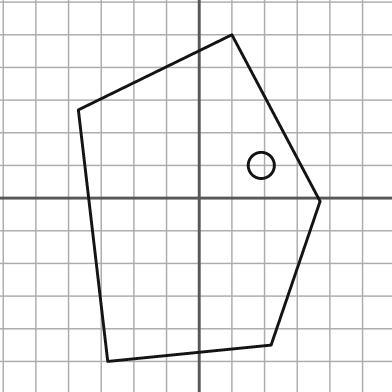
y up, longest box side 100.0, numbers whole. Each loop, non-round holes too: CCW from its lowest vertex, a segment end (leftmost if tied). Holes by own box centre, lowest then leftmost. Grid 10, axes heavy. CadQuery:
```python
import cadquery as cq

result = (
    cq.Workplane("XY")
    .moveTo(-28.0, -50.0)
    .lineTo(22.0, -45.0)
    .lineTo(37.0, -1.0)
    .lineTo(10.0, 50.0)
    .lineTo(-37.0, 27.0)
    .close()
    .moveTo(19.0, 10.0)
    .circle(4.0)
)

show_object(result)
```